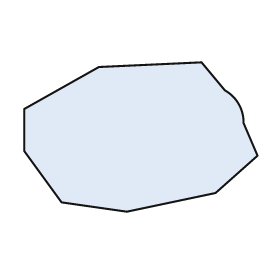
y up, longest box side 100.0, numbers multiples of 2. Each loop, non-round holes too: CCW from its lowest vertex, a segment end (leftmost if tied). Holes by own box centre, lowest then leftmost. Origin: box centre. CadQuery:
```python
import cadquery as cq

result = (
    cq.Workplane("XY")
    .moveTo(-6.0, -32.0)
    .lineTo(32.0, -24.0)
    .lineTo(50.0, -8.0)
    .lineTo(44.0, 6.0)
    .threePointArc((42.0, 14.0), (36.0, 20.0))
    .lineTo(26.0, 32.0)
    .lineTo(-18.0, 30.0)
    .lineTo(-50.0, 12.0)
    .lineTo(-50.0, -6.0)
    .lineTo(-34.0, -28.0)
    .close()
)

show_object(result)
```